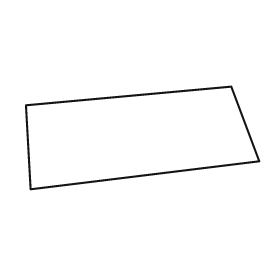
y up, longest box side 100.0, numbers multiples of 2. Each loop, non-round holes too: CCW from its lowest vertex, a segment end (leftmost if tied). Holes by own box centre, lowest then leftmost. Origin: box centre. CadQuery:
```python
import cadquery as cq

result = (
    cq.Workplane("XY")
    .moveTo(-48.0, -22.0)
    .lineTo(50.0, -10.0)
    .lineTo(38.0, 22.0)
    .lineTo(-50.0, 14.0)
    .close()
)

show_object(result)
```